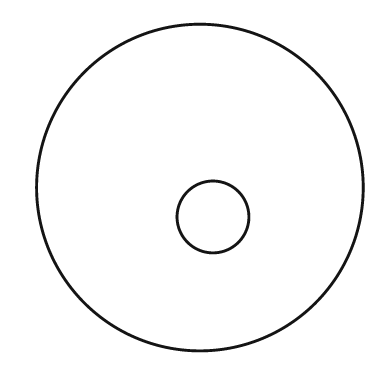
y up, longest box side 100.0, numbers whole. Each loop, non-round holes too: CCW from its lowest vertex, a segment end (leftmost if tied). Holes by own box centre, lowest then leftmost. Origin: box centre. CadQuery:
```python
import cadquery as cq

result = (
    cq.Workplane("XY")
    .moveTo(0.0, 0.0)
    .circle(50.0)
    .moveTo(4.0, -9.0)
    .circle(11.0)
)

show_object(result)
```